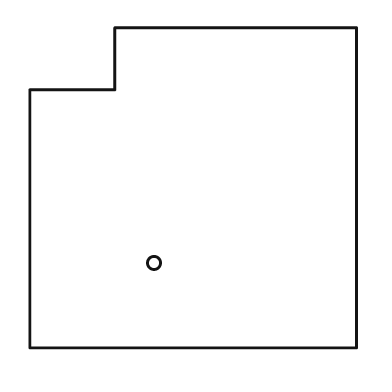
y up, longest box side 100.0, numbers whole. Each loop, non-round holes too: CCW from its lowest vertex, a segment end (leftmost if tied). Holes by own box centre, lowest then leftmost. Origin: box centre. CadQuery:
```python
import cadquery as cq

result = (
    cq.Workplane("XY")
    .moveTo(-50.0, -49.0)
    .lineTo(50.0, -49.0)
    .lineTo(50.0, 49.0)
    .lineTo(-24.0, 49.0)
    .lineTo(-24.0, 30.0)
    .lineTo(-50.0, 30.0)
    .close()
    .moveTo(-12.0, -23.0)
    .circle(2.0)
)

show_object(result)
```